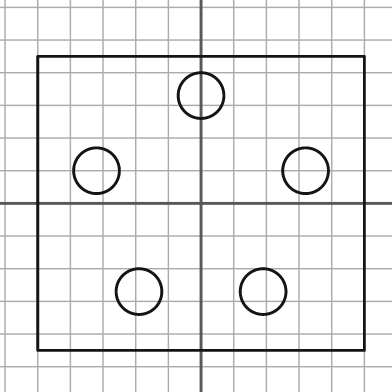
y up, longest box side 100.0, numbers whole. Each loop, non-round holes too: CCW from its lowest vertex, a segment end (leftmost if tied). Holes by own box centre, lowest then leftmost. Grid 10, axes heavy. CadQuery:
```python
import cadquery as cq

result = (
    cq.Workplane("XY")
    .moveTo(-50.0, -45.0)
    .lineTo(50.0, -45.0)
    .lineTo(50.0, 45.0)
    .lineTo(-50.0, 45.0)
    .close()
    .moveTo(-19.0, -27.0)
    .circle(7.0)
    .moveTo(19.0, -27.0)
    .circle(7.0)
    .moveTo(-32.0, 10.0)
    .circle(7.0)
    .moveTo(32.0, 10.0)
    .circle(7.0)
    .moveTo(0.0, 33.0)
    .circle(7.0)
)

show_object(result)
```